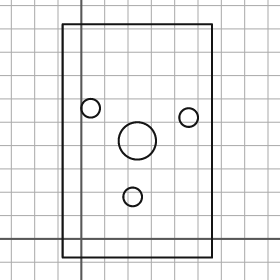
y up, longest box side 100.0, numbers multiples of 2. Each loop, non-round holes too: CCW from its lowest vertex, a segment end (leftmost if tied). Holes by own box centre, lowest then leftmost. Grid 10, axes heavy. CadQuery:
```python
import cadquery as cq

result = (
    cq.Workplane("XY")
    .moveTo(-8.0, -8.0)
    .lineTo(56.0, -8.0)
    .lineTo(56.0, 92.0)
    .lineTo(-8.0, 92.0)
    .close()
    .moveTo(22.0, 18.0)
    .circle(4.0)
    .moveTo(24.0, 42.0)
    .circle(8.0)
    .moveTo(46.0, 52.0)
    .circle(4.0)
    .moveTo(4.0, 56.0)
    .circle(4.0)
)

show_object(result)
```